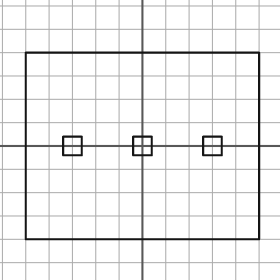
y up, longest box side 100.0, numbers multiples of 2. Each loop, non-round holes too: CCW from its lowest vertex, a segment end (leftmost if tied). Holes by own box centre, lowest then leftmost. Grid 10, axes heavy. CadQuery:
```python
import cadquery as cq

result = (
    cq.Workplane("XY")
    .moveTo(-50.0, -40.0)
    .lineTo(50.0, -40.0)
    .lineTo(50.0, 40.0)
    .lineTo(-50.0, 40.0)
    .close()
    .moveTo(-34.0, -4.0)
    .lineTo(-26.0, -4.0)
    .lineTo(-26.0, 4.0)
    .lineTo(-34.0, 4.0)
    .close()
    .moveTo(-4.0, -4.0)
    .lineTo(4.0, -4.0)
    .lineTo(4.0, 4.0)
    .lineTo(-4.0, 4.0)
    .close()
    .moveTo(26.0, -4.0)
    .lineTo(34.0, -4.0)
    .lineTo(34.0, 4.0)
    .lineTo(26.0, 4.0)
    .close()
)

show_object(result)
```